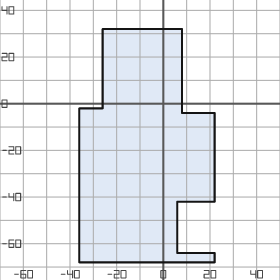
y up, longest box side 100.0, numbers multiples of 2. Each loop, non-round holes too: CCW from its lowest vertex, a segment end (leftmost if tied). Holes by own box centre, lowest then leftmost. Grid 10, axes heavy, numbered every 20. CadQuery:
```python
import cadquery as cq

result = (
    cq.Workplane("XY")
    .moveTo(-36.0, -68.0)
    .lineTo(22.0, -68.0)
    .lineTo(22.0, -64.0)
    .lineTo(6.0, -64.0)
    .lineTo(6.0, -42.0)
    .lineTo(22.0, -42.0)
    .lineTo(22.0, -4.0)
    .lineTo(8.0, -4.0)
    .lineTo(8.0, 32.0)
    .lineTo(-26.0, 32.0)
    .lineTo(-26.0, -2.0)
    .lineTo(-36.0, -2.0)
    .close()
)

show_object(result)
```